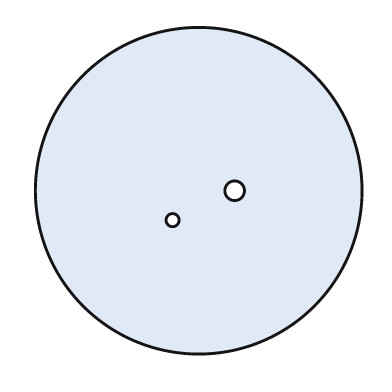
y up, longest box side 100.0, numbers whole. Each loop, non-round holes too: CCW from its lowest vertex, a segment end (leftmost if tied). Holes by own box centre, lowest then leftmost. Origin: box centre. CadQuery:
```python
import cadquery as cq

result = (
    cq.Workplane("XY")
    .moveTo(0.0, 0.0)
    .circle(50.0)
    .moveTo(-8.0, -9.0)
    .circle(2.0)
    .moveTo(11.0, 0.0)
    .circle(3.0)
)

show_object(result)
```